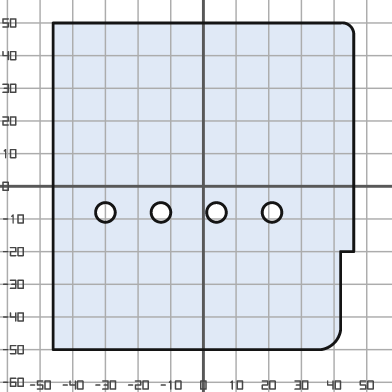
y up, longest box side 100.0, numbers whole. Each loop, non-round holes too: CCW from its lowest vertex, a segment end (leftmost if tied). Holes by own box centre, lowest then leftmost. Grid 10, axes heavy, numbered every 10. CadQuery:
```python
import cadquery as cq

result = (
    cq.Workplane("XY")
    .moveTo(-46.0, -50.0)
    .lineTo(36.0, -50.0)
    .threePointArc((40.0, -48.0), (42.0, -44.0))
    .lineTo(42.0, -20.0)
    .lineTo(46.0, -20.0)
    .lineTo(46.0, 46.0)
    .threePointArc((45.0, 49.0), (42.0, 50.0))
    .lineTo(-46.0, 50.0)
    .close()
    .moveTo(-30.0, -8.0)
    .circle(3.0)
    .moveTo(-13.0, -8.0)
    .circle(3.0)
    .moveTo(4.0, -8.0)
    .circle(3.0)
    .moveTo(21.0, -8.0)
    .circle(3.0)
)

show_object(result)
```